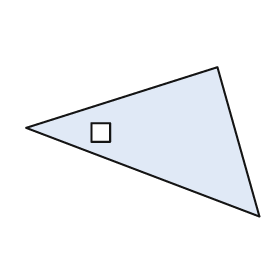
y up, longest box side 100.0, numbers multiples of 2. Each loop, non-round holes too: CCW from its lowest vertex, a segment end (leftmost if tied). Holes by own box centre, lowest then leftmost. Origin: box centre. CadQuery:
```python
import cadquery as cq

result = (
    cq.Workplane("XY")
    .moveTo(50.0, -32.0)
    .lineTo(32.0, 32.0)
    .lineTo(-50.0, 6.0)
    .close()
    .moveTo(-22.0, 0.0)
    .lineTo(-14.0, 0.0)
    .lineTo(-14.0, 8.0)
    .lineTo(-22.0, 8.0)
    .close()
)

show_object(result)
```